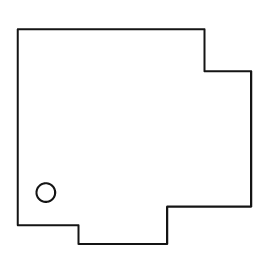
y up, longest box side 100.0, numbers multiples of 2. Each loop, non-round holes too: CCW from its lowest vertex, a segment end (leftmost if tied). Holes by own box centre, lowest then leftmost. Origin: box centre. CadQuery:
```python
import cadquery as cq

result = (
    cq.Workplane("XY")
    .moveTo(-24.0, -46.0)
    .lineTo(14.0, -46.0)
    .lineTo(14.0, -30.0)
    .lineTo(50.0, -30.0)
    .lineTo(50.0, 28.0)
    .lineTo(30.0, 28.0)
    .lineTo(30.0, 46.0)
    .lineTo(-50.0, 46.0)
    .lineTo(-50.0, -38.0)
    .lineTo(-24.0, -38.0)
    .close()
    .moveTo(-38.0, -24.0)
    .circle(4.0)
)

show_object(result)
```